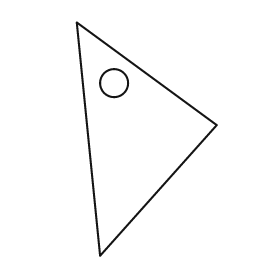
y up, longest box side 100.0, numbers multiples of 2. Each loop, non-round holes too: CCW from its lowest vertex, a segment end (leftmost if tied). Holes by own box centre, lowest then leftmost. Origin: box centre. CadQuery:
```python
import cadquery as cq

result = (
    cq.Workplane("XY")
    .moveTo(-20.0, -50.0)
    .lineTo(30.0, 6.0)
    .lineTo(-30.0, 50.0)
    .close()
    .moveTo(-14.0, 24.0)
    .circle(6.0)
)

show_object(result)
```